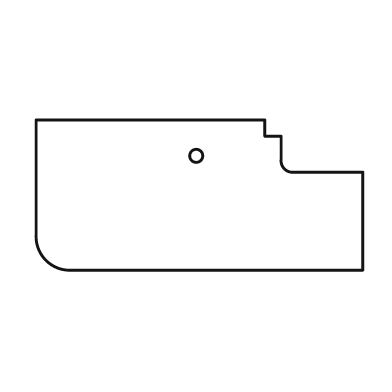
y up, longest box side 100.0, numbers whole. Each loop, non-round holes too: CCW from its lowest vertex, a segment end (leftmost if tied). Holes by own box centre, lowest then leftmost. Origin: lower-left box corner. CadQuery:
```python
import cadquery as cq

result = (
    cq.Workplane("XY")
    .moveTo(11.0, 0.0)
    .lineTo(100.0, 0.0)
    .lineTo(100.0, 30.0)
    .lineTo(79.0, 30.0)
    .threePointArc((76.0, 31.0), (75.0, 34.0))
    .lineTo(75.0, 41.0)
    .lineTo(70.0, 41.0)
    .lineTo(70.0, 46.0)
    .lineTo(0.0, 46.0)
    .lineTo(0.0, 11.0)
    .threePointArc((3.0, 3.0), (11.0, 0.0))
    .close()
    .moveTo(49.0, 35.0)
    .circle(2.0)
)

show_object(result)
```